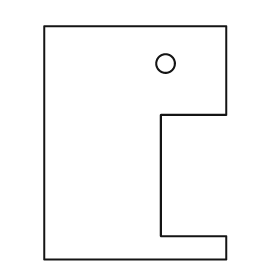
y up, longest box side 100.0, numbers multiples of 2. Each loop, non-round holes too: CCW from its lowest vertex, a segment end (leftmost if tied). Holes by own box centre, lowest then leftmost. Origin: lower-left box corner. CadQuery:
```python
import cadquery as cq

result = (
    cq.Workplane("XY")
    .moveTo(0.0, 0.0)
    .lineTo(78.0, 0.0)
    .lineTo(78.0, 10.0)
    .lineTo(50.0, 10.0)
    .lineTo(50.0, 62.0)
    .lineTo(78.0, 62.0)
    .lineTo(78.0, 100.0)
    .lineTo(0.0, 100.0)
    .close()
    .moveTo(52.0, 84.0)
    .circle(4.0)
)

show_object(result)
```